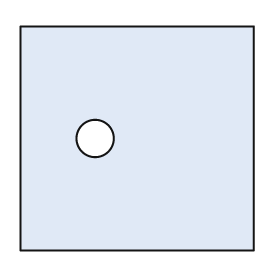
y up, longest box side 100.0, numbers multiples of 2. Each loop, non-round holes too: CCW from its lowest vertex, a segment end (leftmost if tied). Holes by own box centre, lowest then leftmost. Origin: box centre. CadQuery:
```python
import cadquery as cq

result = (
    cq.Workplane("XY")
    .moveTo(-50.0, -48.0)
    .lineTo(50.0, -48.0)
    .lineTo(50.0, 48.0)
    .lineTo(-50.0, 48.0)
    .close()
    .moveTo(-18.0, 0.0)
    .circle(8.0)
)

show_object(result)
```